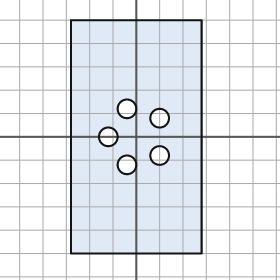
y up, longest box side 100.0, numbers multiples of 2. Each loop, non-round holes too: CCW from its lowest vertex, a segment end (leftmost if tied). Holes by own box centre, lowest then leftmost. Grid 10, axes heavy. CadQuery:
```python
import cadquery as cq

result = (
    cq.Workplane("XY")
    .moveTo(-28.0, -50.0)
    .lineTo(28.0, -50.0)
    .lineTo(28.0, 50.0)
    .lineTo(-28.0, 50.0)
    .close()
    .moveTo(-4.0, -12.0)
    .circle(4.0)
    .moveTo(10.0, -8.0)
    .circle(4.0)
    .moveTo(-12.0, 0.0)
    .circle(4.0)
    .moveTo(10.0, 8.0)
    .circle(4.0)
    .moveTo(-4.0, 12.0)
    .circle(4.0)
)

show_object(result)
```